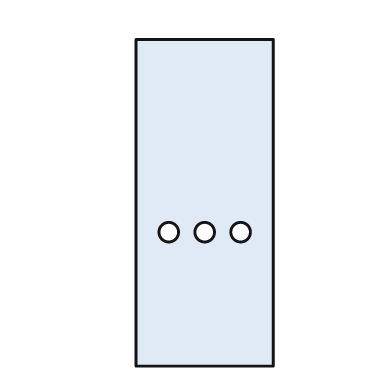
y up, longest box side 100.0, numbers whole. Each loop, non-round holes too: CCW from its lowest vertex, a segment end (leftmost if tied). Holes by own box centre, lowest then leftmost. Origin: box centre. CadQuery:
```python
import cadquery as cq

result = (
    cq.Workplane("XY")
    .moveTo(-21.0, -50.0)
    .lineTo(21.0, -50.0)
    .lineTo(21.0, 50.0)
    .lineTo(-21.0, 50.0)
    .close()
    .moveTo(-11.0, -9.0)
    .circle(3.0)
    .moveTo(0.0, -9.0)
    .circle(3.0)
    .moveTo(11.0, -9.0)
    .circle(3.0)
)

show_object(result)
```